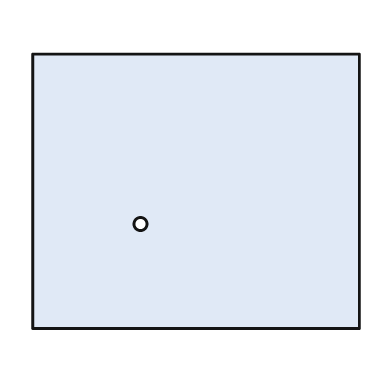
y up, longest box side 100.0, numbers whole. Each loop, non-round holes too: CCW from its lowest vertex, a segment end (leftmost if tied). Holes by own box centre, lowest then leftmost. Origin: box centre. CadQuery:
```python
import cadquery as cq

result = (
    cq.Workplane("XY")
    .moveTo(-50.0, -42.0)
    .lineTo(50.0, -42.0)
    .lineTo(50.0, 42.0)
    .lineTo(-50.0, 42.0)
    .close()
    .moveTo(-17.0, -10.0)
    .circle(2.0)
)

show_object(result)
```